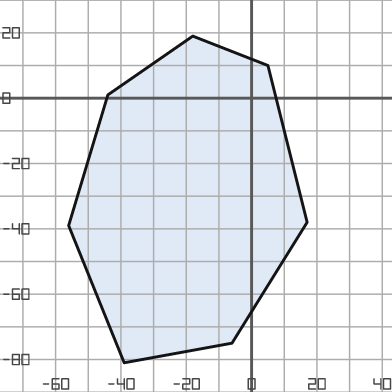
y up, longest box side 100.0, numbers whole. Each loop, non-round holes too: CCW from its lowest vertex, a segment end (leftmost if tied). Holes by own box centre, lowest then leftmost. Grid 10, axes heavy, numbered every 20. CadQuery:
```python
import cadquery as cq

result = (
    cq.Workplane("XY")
    .moveTo(-39.0, -81.0)
    .lineTo(-6.0, -75.0)
    .lineTo(17.0, -38.0)
    .lineTo(5.0, 10.0)
    .lineTo(-18.0, 19.0)
    .lineTo(-44.0, 1.0)
    .lineTo(-56.0, -39.0)
    .close()
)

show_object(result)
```